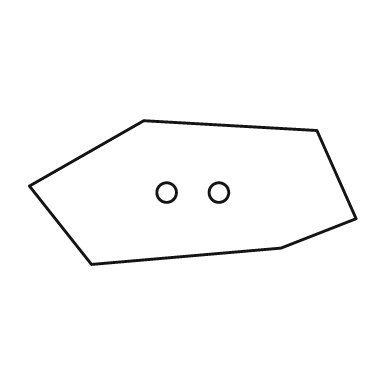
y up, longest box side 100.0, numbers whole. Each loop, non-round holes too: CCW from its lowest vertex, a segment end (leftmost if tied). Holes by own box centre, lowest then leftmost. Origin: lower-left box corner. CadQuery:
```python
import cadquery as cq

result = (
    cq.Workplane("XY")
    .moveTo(19.0, 0.0)
    .lineTo(77.0, 5.0)
    .lineTo(100.0, 14.0)
    .lineTo(88.0, 41.0)
    .lineTo(35.0, 44.0)
    .lineTo(0.0, 24.0)
    .close()
    .moveTo(42.0, 22.0)
    .circle(3.0)
    .moveTo(58.0, 22.0)
    .circle(3.0)
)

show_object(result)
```